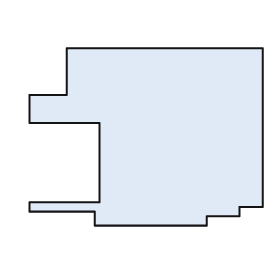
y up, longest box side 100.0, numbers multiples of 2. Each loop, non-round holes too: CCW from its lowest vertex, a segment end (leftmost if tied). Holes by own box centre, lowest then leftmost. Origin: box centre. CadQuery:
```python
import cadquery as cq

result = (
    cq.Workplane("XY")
    .moveTo(-22.0, -38.0)
    .lineTo(26.0, -38.0)
    .lineTo(26.0, -34.0)
    .lineTo(40.0, -34.0)
    .lineTo(40.0, -30.0)
    .lineTo(50.0, -30.0)
    .lineTo(50.0, 38.0)
    .lineTo(-34.0, 38.0)
    .lineTo(-34.0, 18.0)
    .lineTo(-50.0, 18.0)
    .lineTo(-50.0, 6.0)
    .lineTo(-20.0, 6.0)
    .lineTo(-20.0, -28.0)
    .lineTo(-50.0, -28.0)
    .lineTo(-50.0, -32.0)
    .lineTo(-22.0, -32.0)
    .close()
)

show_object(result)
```